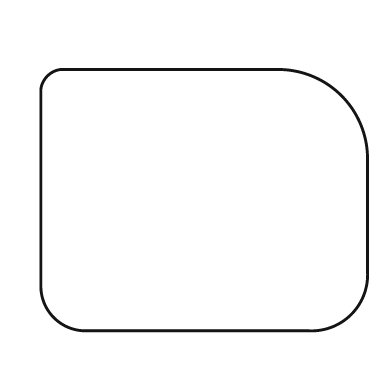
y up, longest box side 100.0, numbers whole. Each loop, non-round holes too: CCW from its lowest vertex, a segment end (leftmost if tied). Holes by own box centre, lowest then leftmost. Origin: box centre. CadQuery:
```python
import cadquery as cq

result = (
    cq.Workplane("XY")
    .moveTo(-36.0, -40.0)
    .lineTo(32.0, -40.0)
    .threePointArc((45.0, -35.0), (50.0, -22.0))
    .lineTo(50.0, 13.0)
    .threePointArc((42.0, 32.0), (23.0, 40.0))
    .lineTo(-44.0, 40.0)
    .threePointArc((-48.0, 38.0), (-50.0, 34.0))
    .lineTo(-50.0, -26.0)
    .threePointArc((-46.0, -36.0), (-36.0, -40.0))
    .close()
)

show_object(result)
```